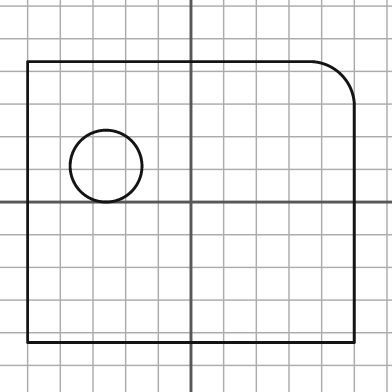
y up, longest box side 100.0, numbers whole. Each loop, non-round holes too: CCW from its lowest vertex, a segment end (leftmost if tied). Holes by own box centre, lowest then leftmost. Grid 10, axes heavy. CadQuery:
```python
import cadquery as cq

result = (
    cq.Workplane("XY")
    .moveTo(-50.0, -43.0)
    .lineTo(50.0, -43.0)
    .lineTo(50.0, 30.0)
    .threePointArc((46.0, 39.0), (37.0, 43.0))
    .lineTo(-50.0, 43.0)
    .close()
    .moveTo(-26.0, 11.0)
    .circle(11.0)
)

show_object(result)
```